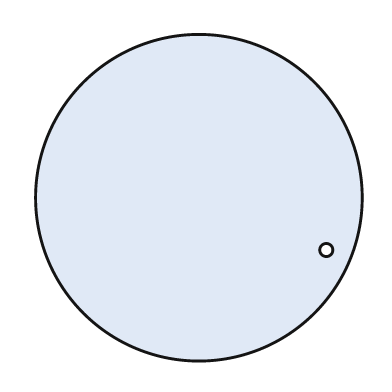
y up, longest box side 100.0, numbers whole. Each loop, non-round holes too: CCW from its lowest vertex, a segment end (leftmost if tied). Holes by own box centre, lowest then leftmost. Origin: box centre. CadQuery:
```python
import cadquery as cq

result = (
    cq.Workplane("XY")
    .moveTo(0.0, 0.0)
    .circle(50.0)
    .moveTo(39.0, -16.0)
    .circle(2.0)
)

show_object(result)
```